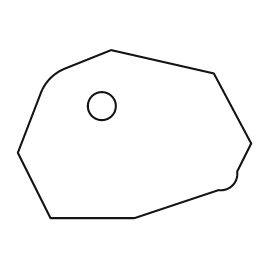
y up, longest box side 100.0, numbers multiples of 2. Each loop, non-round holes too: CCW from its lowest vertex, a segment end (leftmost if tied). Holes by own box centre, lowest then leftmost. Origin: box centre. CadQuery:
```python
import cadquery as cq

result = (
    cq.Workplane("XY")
    .moveTo(-36.0, -36.0)
    .lineTo(0.0, -36.0)
    .lineTo(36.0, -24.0)
    .threePointArc((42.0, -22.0), (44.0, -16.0))
    .lineTo(50.0, -4.0)
    .lineTo(34.0, 26.0)
    .lineTo(-10.0, 36.0)
    .lineTo(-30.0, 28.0)
    .threePointArc((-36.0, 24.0), (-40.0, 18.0))
    .lineTo(-50.0, -8.0)
    .close()
    .moveTo(-14.0, 12.0)
    .circle(6.0)
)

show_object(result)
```